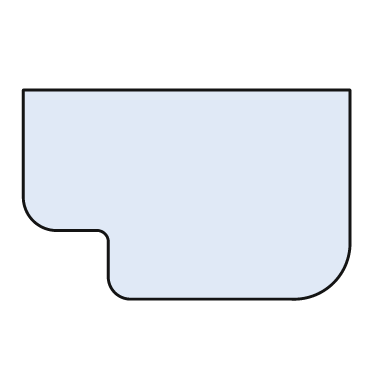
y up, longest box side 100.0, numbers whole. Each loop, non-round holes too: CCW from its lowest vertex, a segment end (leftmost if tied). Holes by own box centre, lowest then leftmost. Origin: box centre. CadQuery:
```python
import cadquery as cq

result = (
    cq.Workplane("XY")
    .moveTo(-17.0, -32.0)
    .lineTo(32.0, -32.0)
    .threePointArc((45.0, -27.0), (50.0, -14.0))
    .lineTo(50.0, 32.0)
    .lineTo(-50.0, 32.0)
    .lineTo(-50.0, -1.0)
    .threePointArc((-47.0, -8.0), (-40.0, -11.0))
    .lineTo(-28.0, -11.0)
    .threePointArc((-25.0, -12.0), (-24.0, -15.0))
    .lineTo(-24.0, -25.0)
    .threePointArc((-22.0, -30.0), (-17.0, -32.0))
    .close()
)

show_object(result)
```